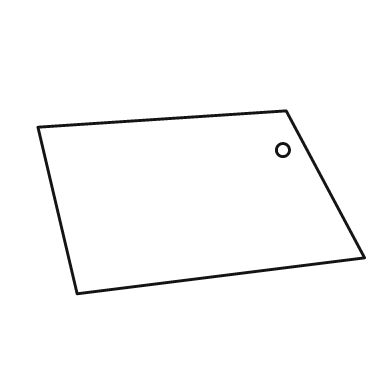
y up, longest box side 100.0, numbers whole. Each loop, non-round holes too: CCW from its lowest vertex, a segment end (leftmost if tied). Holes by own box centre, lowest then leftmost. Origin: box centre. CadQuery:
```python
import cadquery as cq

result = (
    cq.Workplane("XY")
    .moveTo(-38.0, -28.0)
    .lineTo(50.0, -17.0)
    .lineTo(26.0, 28.0)
    .lineTo(-50.0, 23.0)
    .close()
    .moveTo(25.0, 16.0)
    .circle(2.0)
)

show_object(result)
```